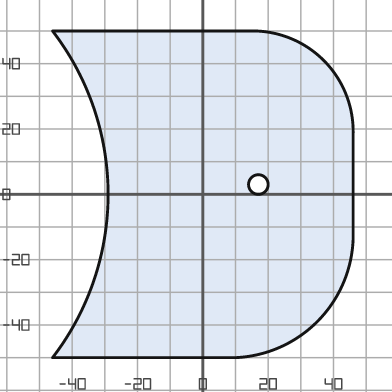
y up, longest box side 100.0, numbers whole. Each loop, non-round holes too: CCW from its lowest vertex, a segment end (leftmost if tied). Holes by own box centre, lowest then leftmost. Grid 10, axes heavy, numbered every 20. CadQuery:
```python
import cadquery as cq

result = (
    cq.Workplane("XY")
    .moveTo(-46.0, -50.0)
    .lineTo(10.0, -50.0)
    .threePointArc((35.0, -39.0), (46.0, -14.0))
    .lineTo(46.0, 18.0)
    .threePointArc((37.0, 41.0), (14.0, 50.0))
    .lineTo(-46.0, 50.0)
    .threePointArc((-29.0, 0.0), (-46.0, -50.0))
    .close()
    .moveTo(17.0, 3.0)
    .circle(3.0)
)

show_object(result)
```